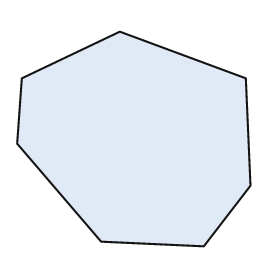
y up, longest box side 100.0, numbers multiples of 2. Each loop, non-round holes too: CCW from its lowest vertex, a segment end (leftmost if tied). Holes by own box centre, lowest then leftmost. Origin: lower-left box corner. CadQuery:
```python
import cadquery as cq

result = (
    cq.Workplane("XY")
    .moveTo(80.0, 0.0)
    .lineTo(100.0, 26.0)
    .lineTo(98.0, 72.0)
    .lineTo(44.0, 92.0)
    .lineTo(2.0, 72.0)
    .lineTo(0.0, 44.0)
    .lineTo(36.0, 2.0)
    .close()
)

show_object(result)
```